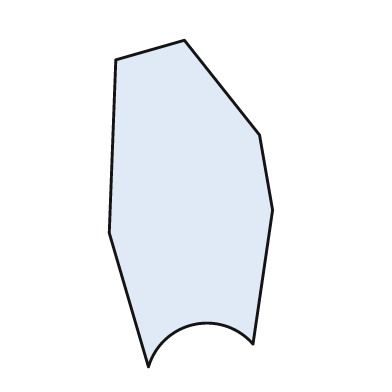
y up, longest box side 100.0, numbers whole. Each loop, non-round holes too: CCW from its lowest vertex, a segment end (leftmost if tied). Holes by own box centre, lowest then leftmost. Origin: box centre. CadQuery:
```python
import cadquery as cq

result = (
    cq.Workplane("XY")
    .moveTo(-13.0, -50.0)
    .threePointArc((1.0, -37.0), (19.0, -43.0))
    .lineTo(25.0, -2.0)
    .lineTo(21.0, 21.0)
    .lineTo(-2.0, 50.0)
    .lineTo(-23.0, 44.0)
    .lineTo(-25.0, -9.0)
    .close()
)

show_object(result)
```